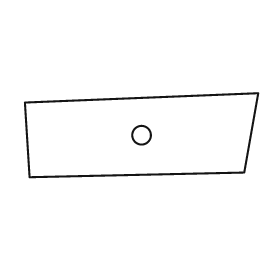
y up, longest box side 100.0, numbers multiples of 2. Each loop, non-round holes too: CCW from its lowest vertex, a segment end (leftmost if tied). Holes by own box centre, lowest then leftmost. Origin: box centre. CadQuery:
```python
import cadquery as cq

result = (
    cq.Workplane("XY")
    .moveTo(-48.0, -18.0)
    .lineTo(44.0, -16.0)
    .lineTo(50.0, 18.0)
    .lineTo(-50.0, 14.0)
    .close()
    .moveTo(0.0, 0.0)
    .circle(4.0)
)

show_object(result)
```